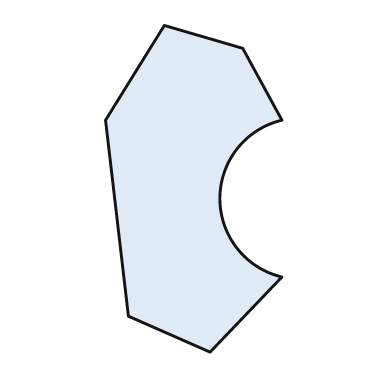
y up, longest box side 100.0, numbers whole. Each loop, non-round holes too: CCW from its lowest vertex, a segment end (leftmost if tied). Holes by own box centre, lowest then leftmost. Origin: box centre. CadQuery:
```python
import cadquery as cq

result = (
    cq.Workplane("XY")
    .moveTo(5.0, -50.0)
    .lineTo(27.0, -27.0)
    .threePointArc((8.0, -3.0), (27.0, 21.0))
    .lineTo(15.0, 43.0)
    .lineTo(-9.0, 50.0)
    .lineTo(-27.0, 21.0)
    .lineTo(-20.0, -39.0)
    .close()
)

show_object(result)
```